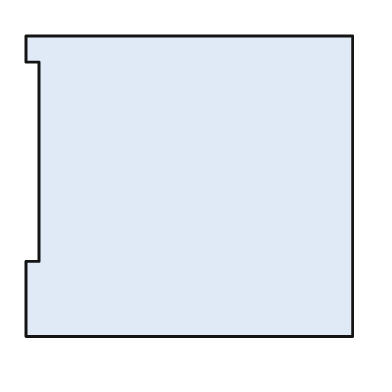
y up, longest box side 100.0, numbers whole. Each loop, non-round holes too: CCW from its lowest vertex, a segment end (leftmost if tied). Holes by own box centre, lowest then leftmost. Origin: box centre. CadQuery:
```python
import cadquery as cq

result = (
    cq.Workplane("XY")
    .moveTo(-50.0, -46.0)
    .lineTo(50.0, -46.0)
    .lineTo(50.0, 46.0)
    .lineTo(-50.0, 46.0)
    .lineTo(-50.0, 38.0)
    .lineTo(-46.0, 38.0)
    .lineTo(-46.0, -23.0)
    .lineTo(-50.0, -23.0)
    .close()
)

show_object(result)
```